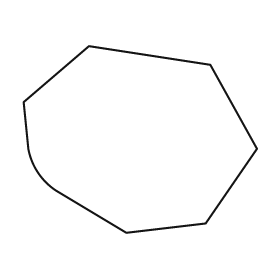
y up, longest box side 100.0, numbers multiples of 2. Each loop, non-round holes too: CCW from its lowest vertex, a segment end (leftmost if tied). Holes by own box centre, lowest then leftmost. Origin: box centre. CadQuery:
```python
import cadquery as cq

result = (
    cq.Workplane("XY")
    .moveTo(-6.0, -40.0)
    .lineTo(28.0, -36.0)
    .lineTo(50.0, -4.0)
    .lineTo(30.0, 32.0)
    .lineTo(-22.0, 40.0)
    .lineTo(-50.0, 16.0)
    .lineTo(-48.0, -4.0)
    .threePointArc((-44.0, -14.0), (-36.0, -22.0))
    .close()
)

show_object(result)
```